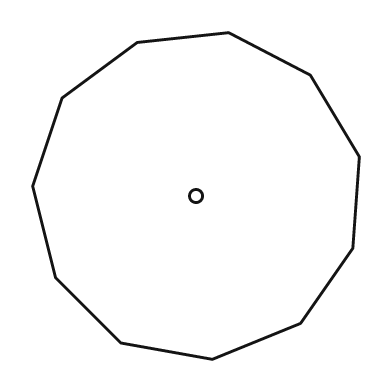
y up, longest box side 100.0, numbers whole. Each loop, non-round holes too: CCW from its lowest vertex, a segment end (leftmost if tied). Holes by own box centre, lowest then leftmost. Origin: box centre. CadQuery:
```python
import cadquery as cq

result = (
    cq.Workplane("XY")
    .moveTo(5.0, -50.0)
    .lineTo(32.0, -39.0)
    .lineTo(48.0, -16.0)
    .lineTo(50.0, 12.0)
    .lineTo(35.0, 37.0)
    .lineTo(10.0, 50.0)
    .lineTo(-18.0, 47.0)
    .lineTo(-41.0, 30.0)
    .lineTo(-50.0, 3.0)
    .lineTo(-43.0, -25.0)
    .lineTo(-23.0, -45.0)
    .close()
    .moveTo(0.0, 0.0)
    .circle(2.0)
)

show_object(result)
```